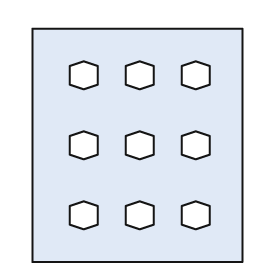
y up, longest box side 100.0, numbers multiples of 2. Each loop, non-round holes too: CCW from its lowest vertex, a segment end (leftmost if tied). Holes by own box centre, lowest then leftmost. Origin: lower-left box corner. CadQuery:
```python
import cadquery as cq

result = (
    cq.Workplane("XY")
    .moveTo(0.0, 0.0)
    .lineTo(90.0, 0.0)
    .lineTo(90.0, 100.0)
    .lineTo(0.0, 100.0)
    .close()
    .moveTo(22.0, 14.0)
    .lineTo(28.0, 16.0)
    .lineTo(28.0, 24.0)
    .lineTo(22.0, 26.0)
    .lineTo(16.0, 24.0)
    .lineTo(16.0, 16.0)
    .close()
    .moveTo(46.0, 14.0)
    .lineTo(52.0, 16.0)
    .lineTo(52.0, 24.0)
    .lineTo(46.0, 26.0)
    .lineTo(40.0, 24.0)
    .lineTo(40.0, 16.0)
    .close()
    .moveTo(70.0, 14.0)
    .lineTo(76.0, 16.0)
    .lineTo(76.0, 24.0)
    .lineTo(70.0, 26.0)
    .lineTo(64.0, 24.0)
    .lineTo(64.0, 16.0)
    .close()
    .moveTo(22.0, 44.0)
    .lineTo(28.0, 46.0)
    .lineTo(28.0, 54.0)
    .lineTo(22.0, 56.0)
    .lineTo(16.0, 54.0)
    .lineTo(16.0, 46.0)
    .close()
    .moveTo(46.0, 44.0)
    .lineTo(52.0, 46.0)
    .lineTo(52.0, 54.0)
    .lineTo(46.0, 56.0)
    .lineTo(40.0, 54.0)
    .lineTo(40.0, 46.0)
    .close()
    .moveTo(70.0, 44.0)
    .lineTo(76.0, 46.0)
    .lineTo(76.0, 54.0)
    .lineTo(70.0, 56.0)
    .lineTo(64.0, 54.0)
    .lineTo(64.0, 46.0)
    .close()
    .moveTo(22.0, 74.0)
    .lineTo(28.0, 76.0)
    .lineTo(28.0, 84.0)
    .lineTo(22.0, 86.0)
    .lineTo(16.0, 84.0)
    .lineTo(16.0, 76.0)
    .close()
    .moveTo(46.0, 74.0)
    .lineTo(52.0, 76.0)
    .lineTo(52.0, 84.0)
    .lineTo(46.0, 86.0)
    .lineTo(40.0, 84.0)
    .lineTo(40.0, 76.0)
    .close()
    .moveTo(70.0, 74.0)
    .lineTo(76.0, 76.0)
    .lineTo(76.0, 84.0)
    .lineTo(70.0, 86.0)
    .lineTo(64.0, 84.0)
    .lineTo(64.0, 76.0)
    .close()
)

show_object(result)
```